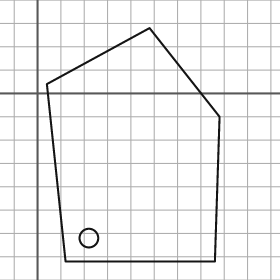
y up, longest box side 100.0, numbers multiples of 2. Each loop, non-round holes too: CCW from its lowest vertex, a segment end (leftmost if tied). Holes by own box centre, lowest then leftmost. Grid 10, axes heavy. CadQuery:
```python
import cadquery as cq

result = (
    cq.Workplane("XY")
    .moveTo(12.0, -72.0)
    .lineTo(76.0, -72.0)
    .lineTo(78.0, -10.0)
    .lineTo(48.0, 28.0)
    .lineTo(4.0, 4.0)
    .close()
    .moveTo(22.0, -62.0)
    .circle(4.0)
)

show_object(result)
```